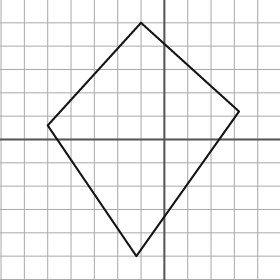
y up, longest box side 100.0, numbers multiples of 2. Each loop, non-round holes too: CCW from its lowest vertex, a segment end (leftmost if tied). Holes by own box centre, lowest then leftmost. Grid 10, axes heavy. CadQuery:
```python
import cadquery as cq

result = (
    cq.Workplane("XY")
    .moveTo(-12.0, -50.0)
    .lineTo(32.0, 12.0)
    .lineTo(-10.0, 50.0)
    .lineTo(-50.0, 6.0)
    .close()
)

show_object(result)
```